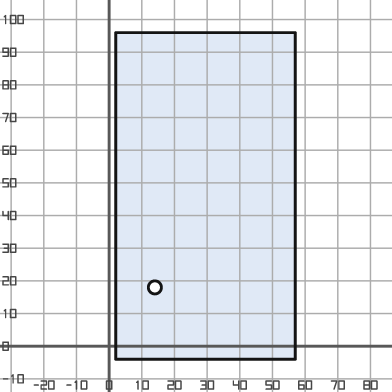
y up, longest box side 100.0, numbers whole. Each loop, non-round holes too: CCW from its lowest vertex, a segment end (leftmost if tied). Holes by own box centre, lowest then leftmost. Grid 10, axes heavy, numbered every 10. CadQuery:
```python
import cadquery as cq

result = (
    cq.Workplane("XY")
    .moveTo(2.0, -4.0)
    .lineTo(57.0, -4.0)
    .lineTo(57.0, 96.0)
    .lineTo(2.0, 96.0)
    .close()
    .moveTo(14.0, 18.0)
    .circle(2.0)
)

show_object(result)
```